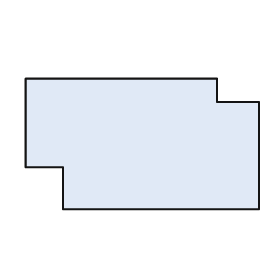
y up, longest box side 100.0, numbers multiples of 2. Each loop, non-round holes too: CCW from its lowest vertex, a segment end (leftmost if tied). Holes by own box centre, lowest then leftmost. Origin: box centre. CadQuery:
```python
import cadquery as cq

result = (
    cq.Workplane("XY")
    .moveTo(-34.0, -28.0)
    .lineTo(50.0, -28.0)
    .lineTo(50.0, 18.0)
    .lineTo(32.0, 18.0)
    .lineTo(32.0, 28.0)
    .lineTo(-50.0, 28.0)
    .lineTo(-50.0, -10.0)
    .lineTo(-34.0, -10.0)
    .close()
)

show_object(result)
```